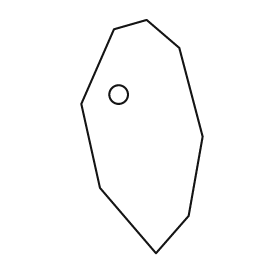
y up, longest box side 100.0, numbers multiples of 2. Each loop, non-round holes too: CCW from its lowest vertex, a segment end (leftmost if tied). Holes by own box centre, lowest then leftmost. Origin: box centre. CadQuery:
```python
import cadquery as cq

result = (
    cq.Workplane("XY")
    .moveTo(6.0, -50.0)
    .lineTo(20.0, -34.0)
    .lineTo(26.0, 0.0)
    .lineTo(16.0, 38.0)
    .lineTo(2.0, 50.0)
    .lineTo(-12.0, 46.0)
    .lineTo(-26.0, 14.0)
    .lineTo(-18.0, -22.0)
    .close()
    .moveTo(-10.0, 18.0)
    .circle(4.0)
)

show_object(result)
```